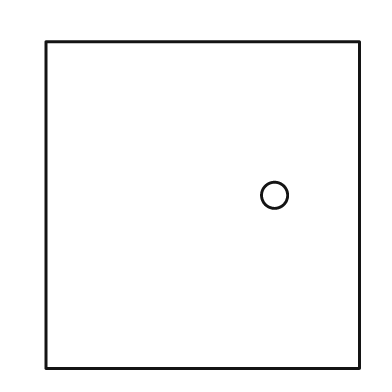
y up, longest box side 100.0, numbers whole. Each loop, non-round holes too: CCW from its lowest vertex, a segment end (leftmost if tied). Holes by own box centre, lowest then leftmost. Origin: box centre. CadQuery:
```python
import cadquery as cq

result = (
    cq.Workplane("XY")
    .moveTo(-48.0, -50.0)
    .lineTo(48.0, -50.0)
    .lineTo(48.0, 50.0)
    .lineTo(-48.0, 50.0)
    .close()
    .moveTo(22.0, 3.0)
    .circle(4.0)
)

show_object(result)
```